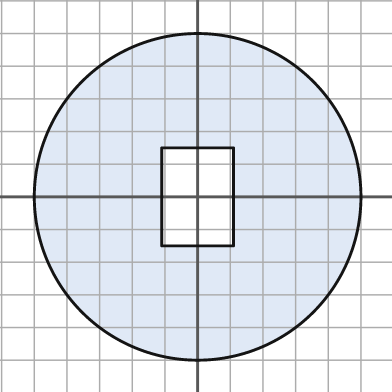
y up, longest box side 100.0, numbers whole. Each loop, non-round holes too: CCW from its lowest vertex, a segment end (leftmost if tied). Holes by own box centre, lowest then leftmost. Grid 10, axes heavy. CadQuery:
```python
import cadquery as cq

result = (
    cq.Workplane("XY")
    .moveTo(0.0, 0.0)
    .circle(50.0)
    .moveTo(-11.0, -15.0)
    .lineTo(11.0, -15.0)
    .lineTo(11.0, 15.0)
    .lineTo(-11.0, 15.0)
    .close()
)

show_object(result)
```